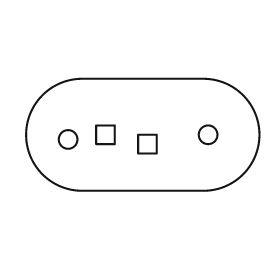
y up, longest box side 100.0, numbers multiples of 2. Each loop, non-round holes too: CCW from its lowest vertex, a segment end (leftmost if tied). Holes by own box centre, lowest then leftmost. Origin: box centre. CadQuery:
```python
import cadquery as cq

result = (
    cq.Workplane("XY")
    .moveTo(-26.0, -24.0)
    .lineTo(26.0, -24.0)
    .threePointArc((50.0, 0.0), (26.0, 24.0))
    .lineTo(-26.0, 24.0)
    .threePointArc((-50.0, 0.0), (-26.0, -24.0))
    .close()
    .moveTo(-2.0, -8.0)
    .lineTo(6.0, -8.0)
    .lineTo(6.0, 0.0)
    .lineTo(-2.0, 0.0)
    .close()
    .moveTo(-32.0, -2.0)
    .circle(4.0)
    .moveTo(-20.0, -4.0)
    .lineTo(-12.0, -4.0)
    .lineTo(-12.0, 4.0)
    .lineTo(-20.0, 4.0)
    .close()
    .moveTo(28.0, 0.0)
    .circle(4.0)
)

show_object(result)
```